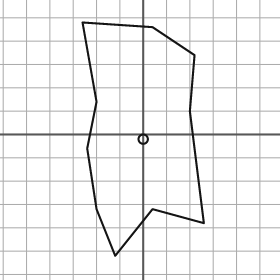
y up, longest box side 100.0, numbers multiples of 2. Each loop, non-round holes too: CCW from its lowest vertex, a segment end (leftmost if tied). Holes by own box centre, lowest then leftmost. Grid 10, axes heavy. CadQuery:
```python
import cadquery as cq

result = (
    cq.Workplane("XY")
    .moveTo(-12.0, -52.0)
    .lineTo(4.0, -32.0)
    .lineTo(26.0, -38.0)
    .lineTo(20.0, 10.0)
    .lineTo(22.0, 34.0)
    .lineTo(4.0, 46.0)
    .lineTo(-26.0, 48.0)
    .lineTo(-20.0, 14.0)
    .lineTo(-24.0, -6.0)
    .lineTo(-20.0, -32.0)
    .close()
    .moveTo(0.0, -2.0)
    .circle(2.0)
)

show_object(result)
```